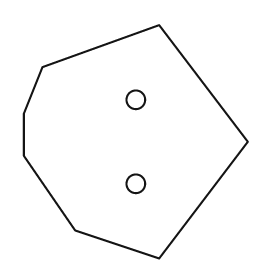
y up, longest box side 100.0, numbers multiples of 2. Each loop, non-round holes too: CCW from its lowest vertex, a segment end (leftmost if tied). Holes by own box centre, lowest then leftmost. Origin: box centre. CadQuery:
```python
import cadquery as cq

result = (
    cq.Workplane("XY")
    .moveTo(10.0, -50.0)
    .lineTo(48.0, 0.0)
    .lineTo(10.0, 50.0)
    .lineTo(-40.0, 32.0)
    .lineTo(-48.0, 12.0)
    .lineTo(-48.0, -6.0)
    .lineTo(-26.0, -38.0)
    .close()
    .moveTo(0.0, -18.0)
    .circle(4.0)
    .moveTo(0.0, 18.0)
    .circle(4.0)
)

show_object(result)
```